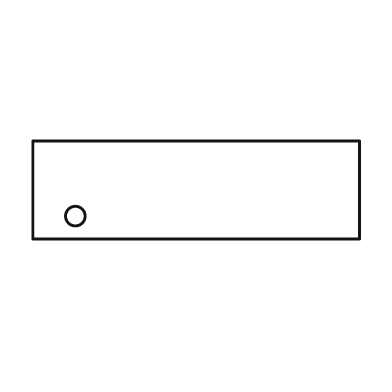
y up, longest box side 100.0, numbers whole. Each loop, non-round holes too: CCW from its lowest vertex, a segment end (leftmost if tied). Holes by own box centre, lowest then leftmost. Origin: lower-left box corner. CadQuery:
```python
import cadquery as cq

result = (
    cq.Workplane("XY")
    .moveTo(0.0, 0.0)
    .lineTo(100.0, 0.0)
    .lineTo(100.0, 30.0)
    .lineTo(0.0, 30.0)
    .close()
    .moveTo(13.0, 7.0)
    .circle(3.0)
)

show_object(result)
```